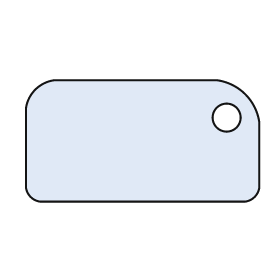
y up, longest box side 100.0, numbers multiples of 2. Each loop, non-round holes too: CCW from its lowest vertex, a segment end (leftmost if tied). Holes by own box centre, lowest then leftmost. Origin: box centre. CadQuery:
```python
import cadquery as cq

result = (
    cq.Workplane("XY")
    .moveTo(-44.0, -26.0)
    .lineTo(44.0, -26.0)
    .threePointArc((48.0, -24.0), (50.0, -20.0))
    .lineTo(50.0, 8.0)
    .threePointArc((44.0, 20.0), (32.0, 26.0))
    .lineTo(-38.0, 26.0)
    .threePointArc((-46.0, 22.0), (-50.0, 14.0))
    .lineTo(-50.0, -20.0)
    .threePointArc((-48.0, -24.0), (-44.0, -26.0))
    .close()
    .moveTo(36.0, 10.0)
    .circle(6.0)
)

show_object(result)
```